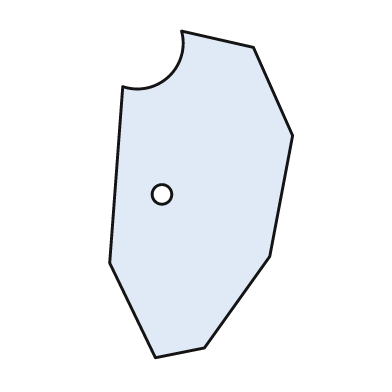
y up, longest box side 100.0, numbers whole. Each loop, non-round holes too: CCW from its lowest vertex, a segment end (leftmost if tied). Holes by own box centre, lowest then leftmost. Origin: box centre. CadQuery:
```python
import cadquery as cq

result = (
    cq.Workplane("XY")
    .moveTo(-14.0, -50.0)
    .lineTo(1.0, -47.0)
    .lineTo(21.0, -19.0)
    .lineTo(28.0, 18.0)
    .lineTo(16.0, 45.0)
    .lineTo(-6.0, 50.0)
    .threePointArc((-10.0, 36.0), (-24.0, 33.0))
    .lineTo(-28.0, -21.0)
    .close()
    .moveTo(-12.0, 0.0)
    .circle(3.0)
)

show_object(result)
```